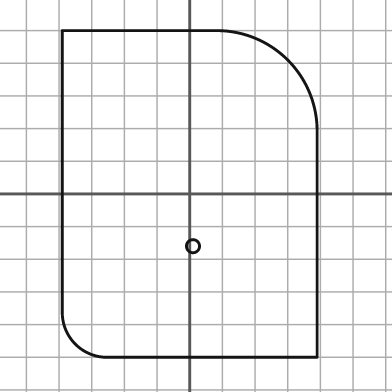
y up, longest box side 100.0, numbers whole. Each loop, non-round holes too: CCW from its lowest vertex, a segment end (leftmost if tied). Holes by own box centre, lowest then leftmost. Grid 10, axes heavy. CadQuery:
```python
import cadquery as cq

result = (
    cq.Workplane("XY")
    .moveTo(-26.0, -50.0)
    .lineTo(39.0, -50.0)
    .lineTo(39.0, 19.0)
    .threePointArc((30.0, 41.0), (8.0, 50.0))
    .lineTo(-39.0, 50.0)
    .lineTo(-39.0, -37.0)
    .threePointArc((-35.0, -46.0), (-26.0, -50.0))
    .close()
    .moveTo(1.0, -16.0)
    .circle(2.0)
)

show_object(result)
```